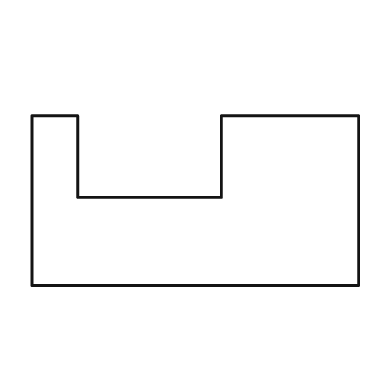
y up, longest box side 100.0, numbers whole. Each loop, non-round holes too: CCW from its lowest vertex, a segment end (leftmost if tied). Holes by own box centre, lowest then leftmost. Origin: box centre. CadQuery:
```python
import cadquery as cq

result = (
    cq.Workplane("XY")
    .moveTo(-50.0, -26.0)
    .lineTo(50.0, -26.0)
    .lineTo(50.0, 26.0)
    .lineTo(8.0, 26.0)
    .lineTo(8.0, 1.0)
    .lineTo(-36.0, 1.0)
    .lineTo(-36.0, 26.0)
    .lineTo(-50.0, 26.0)
    .close()
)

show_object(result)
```